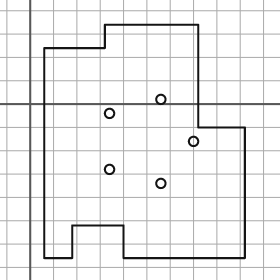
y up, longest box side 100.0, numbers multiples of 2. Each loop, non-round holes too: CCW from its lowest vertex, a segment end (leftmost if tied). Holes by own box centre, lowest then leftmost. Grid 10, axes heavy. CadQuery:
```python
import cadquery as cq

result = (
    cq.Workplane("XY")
    .moveTo(6.0, -66.0)
    .lineTo(18.0, -66.0)
    .lineTo(18.0, -52.0)
    .lineTo(40.0, -52.0)
    .lineTo(40.0, -66.0)
    .lineTo(92.0, -66.0)
    .lineTo(92.0, -10.0)
    .lineTo(72.0, -10.0)
    .lineTo(72.0, 34.0)
    .lineTo(32.0, 34.0)
    .lineTo(32.0, 24.0)
    .lineTo(6.0, 24.0)
    .close()
    .moveTo(56.0, -34.0)
    .circle(2.0)
    .moveTo(34.0, -28.0)
    .circle(2.0)
    .moveTo(70.0, -16.0)
    .circle(2.0)
    .moveTo(34.0, -4.0)
    .circle(2.0)
    .moveTo(56.0, 2.0)
    .circle(2.0)
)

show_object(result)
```